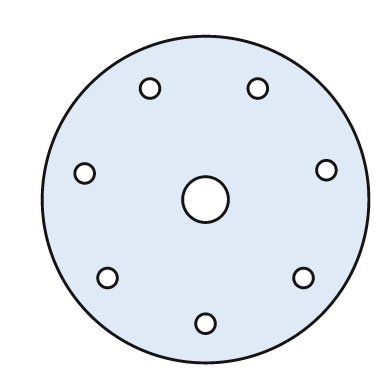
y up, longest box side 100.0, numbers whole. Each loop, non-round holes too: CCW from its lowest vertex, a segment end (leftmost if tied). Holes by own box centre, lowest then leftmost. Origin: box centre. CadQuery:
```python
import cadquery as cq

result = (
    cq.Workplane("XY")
    .moveTo(0.0, 0.0)
    .circle(50.0)
    .moveTo(0.0, -38.0)
    .circle(3.0)
    .moveTo(-30.0, -24.0)
    .circle(3.0)
    .moveTo(30.0, -24.0)
    .circle(3.0)
    .moveTo(0.0, 0.0)
    .circle(7.0)
    .moveTo(-37.0, 8.0)
    .circle(3.0)
    .moveTo(37.0, 9.0)
    .circle(3.0)
    .moveTo(-17.0, 34.0)
    .circle(3.0)
    .moveTo(16.0, 34.0)
    .circle(3.0)
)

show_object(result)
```